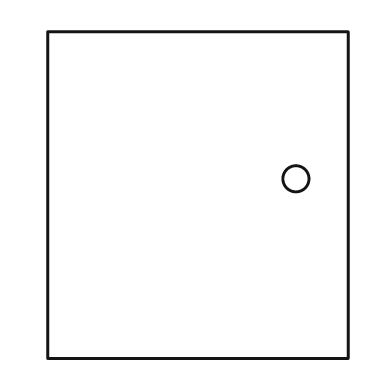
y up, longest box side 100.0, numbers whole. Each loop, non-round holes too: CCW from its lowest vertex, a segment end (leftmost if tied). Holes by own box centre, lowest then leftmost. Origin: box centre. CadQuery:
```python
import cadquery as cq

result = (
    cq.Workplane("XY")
    .moveTo(-46.0, -50.0)
    .lineTo(46.0, -50.0)
    .lineTo(46.0, 50.0)
    .lineTo(-46.0, 50.0)
    .close()
    .moveTo(30.0, 5.0)
    .circle(4.0)
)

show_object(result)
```